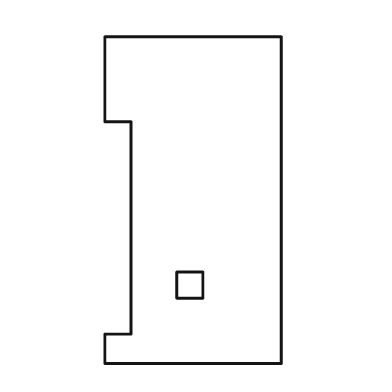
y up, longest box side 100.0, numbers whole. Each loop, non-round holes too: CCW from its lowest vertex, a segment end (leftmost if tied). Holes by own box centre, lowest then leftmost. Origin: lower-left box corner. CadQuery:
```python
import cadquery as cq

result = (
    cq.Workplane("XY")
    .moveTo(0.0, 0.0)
    .lineTo(54.0, 0.0)
    .lineTo(54.0, 100.0)
    .lineTo(0.0, 100.0)
    .lineTo(0.0, 74.0)
    .lineTo(8.0, 74.0)
    .lineTo(8.0, 9.0)
    .lineTo(0.0, 9.0)
    .close()
    .moveTo(22.0, 20.0)
    .lineTo(30.0, 20.0)
    .lineTo(30.0, 28.0)
    .lineTo(22.0, 28.0)
    .close()
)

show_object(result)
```